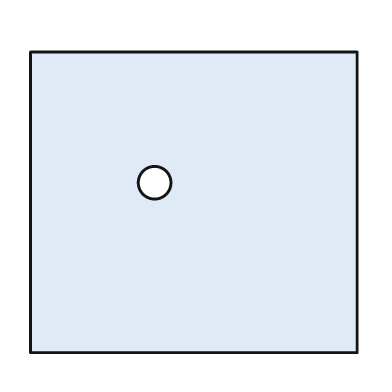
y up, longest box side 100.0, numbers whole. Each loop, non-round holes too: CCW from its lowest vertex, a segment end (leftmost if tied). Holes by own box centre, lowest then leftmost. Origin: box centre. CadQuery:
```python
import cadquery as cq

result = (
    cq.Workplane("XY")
    .moveTo(-50.0, -46.0)
    .lineTo(50.0, -46.0)
    .lineTo(50.0, 46.0)
    .lineTo(-50.0, 46.0)
    .close()
    .moveTo(-12.0, 6.0)
    .circle(5.0)
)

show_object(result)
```